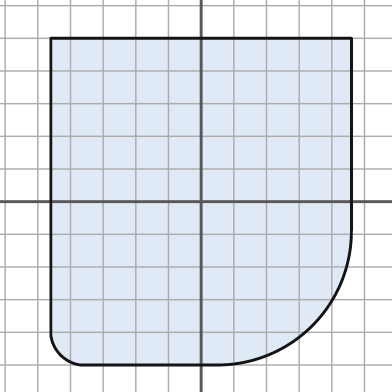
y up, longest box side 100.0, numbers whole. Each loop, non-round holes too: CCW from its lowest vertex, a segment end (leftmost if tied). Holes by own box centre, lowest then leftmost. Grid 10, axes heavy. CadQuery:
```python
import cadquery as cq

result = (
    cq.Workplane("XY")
    .moveTo(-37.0, -50.0)
    .lineTo(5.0, -50.0)
    .threePointArc((34.0, -38.0), (46.0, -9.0))
    .lineTo(46.0, 50.0)
    .lineTo(-46.0, 50.0)
    .lineTo(-46.0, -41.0)
    .threePointArc((-43.0, -47.0), (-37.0, -50.0))
    .close()
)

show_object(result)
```